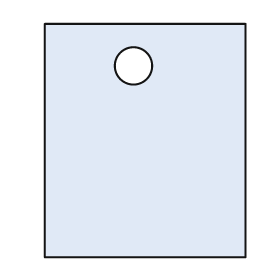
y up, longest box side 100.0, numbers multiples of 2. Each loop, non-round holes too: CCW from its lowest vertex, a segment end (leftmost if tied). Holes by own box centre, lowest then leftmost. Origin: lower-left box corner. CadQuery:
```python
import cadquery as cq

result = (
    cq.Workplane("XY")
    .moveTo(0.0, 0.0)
    .lineTo(86.0, 0.0)
    .lineTo(86.0, 100.0)
    .lineTo(0.0, 100.0)
    .close()
    .moveTo(38.0, 82.0)
    .circle(8.0)
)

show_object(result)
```